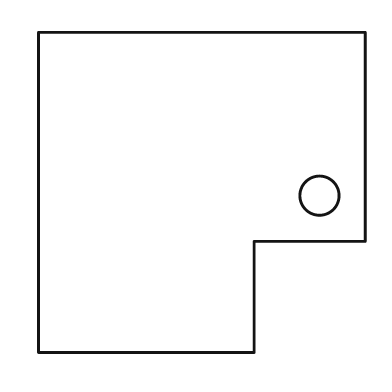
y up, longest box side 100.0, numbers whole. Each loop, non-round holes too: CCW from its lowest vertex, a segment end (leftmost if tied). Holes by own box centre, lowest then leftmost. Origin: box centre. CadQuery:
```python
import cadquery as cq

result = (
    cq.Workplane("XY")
    .moveTo(-50.0, -49.0)
    .lineTo(16.0, -49.0)
    .lineTo(16.0, -15.0)
    .lineTo(50.0, -15.0)
    .lineTo(50.0, 49.0)
    .lineTo(-50.0, 49.0)
    .close()
    .moveTo(36.0, -1.0)
    .circle(6.0)
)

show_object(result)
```